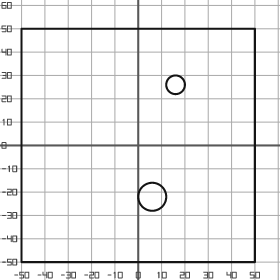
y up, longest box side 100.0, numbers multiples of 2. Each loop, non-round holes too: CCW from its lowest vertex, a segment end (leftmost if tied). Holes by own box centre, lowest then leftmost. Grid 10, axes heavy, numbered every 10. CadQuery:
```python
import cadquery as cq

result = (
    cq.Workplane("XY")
    .moveTo(-50.0, -50.0)
    .lineTo(50.0, -50.0)
    .lineTo(50.0, 50.0)
    .lineTo(-50.0, 50.0)
    .close()
    .moveTo(6.0, -22.0)
    .circle(6.0)
    .moveTo(16.0, 26.0)
    .circle(4.0)
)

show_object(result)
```